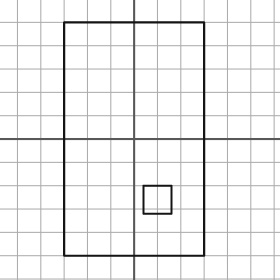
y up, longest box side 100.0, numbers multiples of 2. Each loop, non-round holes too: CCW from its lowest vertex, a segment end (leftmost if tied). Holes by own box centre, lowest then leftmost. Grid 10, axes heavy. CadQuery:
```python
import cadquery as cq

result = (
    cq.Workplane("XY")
    .moveTo(-30.0, -50.0)
    .lineTo(30.0, -50.0)
    .lineTo(30.0, 50.0)
    .lineTo(-30.0, 50.0)
    .close()
    .moveTo(4.0, -32.0)
    .lineTo(16.0, -32.0)
    .lineTo(16.0, -20.0)
    .lineTo(4.0, -20.0)
    .close()
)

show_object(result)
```